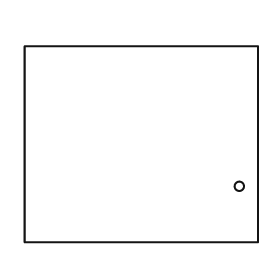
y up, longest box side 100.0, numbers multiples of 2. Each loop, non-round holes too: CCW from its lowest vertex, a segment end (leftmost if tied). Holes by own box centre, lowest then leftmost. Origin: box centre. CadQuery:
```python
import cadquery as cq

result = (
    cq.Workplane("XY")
    .moveTo(-50.0, -42.0)
    .lineTo(50.0, -42.0)
    .lineTo(50.0, 42.0)
    .lineTo(-50.0, 42.0)
    .close()
    .moveTo(42.0, -18.0)
    .circle(2.0)
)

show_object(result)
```